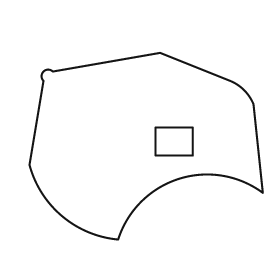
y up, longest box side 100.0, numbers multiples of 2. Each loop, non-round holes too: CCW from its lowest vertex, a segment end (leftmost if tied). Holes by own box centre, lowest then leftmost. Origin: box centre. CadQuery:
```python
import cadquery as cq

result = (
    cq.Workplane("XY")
    .moveTo(-12.0, -40.0)
    .threePointArc((14.0, -14.0), (50.0, -20.0))
    .lineTo(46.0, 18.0)
    .threePointArc((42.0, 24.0), (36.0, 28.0))
    .lineTo(6.0, 40.0)
    .lineTo(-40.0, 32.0)
    .threePointArc((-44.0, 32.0), (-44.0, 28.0))
    .lineTo(-50.0, -8.0)
    .threePointArc((-36.0, -30.0), (-12.0, -40.0))
    .close()
    .moveTo(4.0, -4.0)
    .lineTo(20.0, -4.0)
    .lineTo(20.0, 8.0)
    .lineTo(4.0, 8.0)
    .close()
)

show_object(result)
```